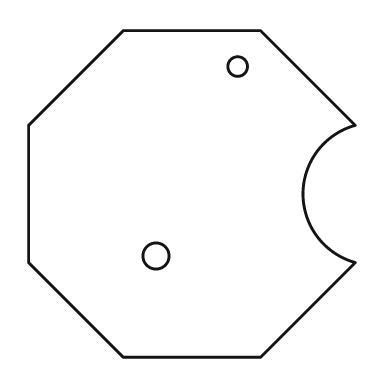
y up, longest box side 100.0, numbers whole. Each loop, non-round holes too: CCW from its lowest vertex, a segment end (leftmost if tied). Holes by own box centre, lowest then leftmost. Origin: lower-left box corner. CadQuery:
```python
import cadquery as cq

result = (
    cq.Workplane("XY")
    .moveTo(29.0, 0.0)
    .lineTo(71.0, 0.0)
    .lineTo(100.0, 29.0)
    .threePointArc((84.0, 50.0), (100.0, 71.0))
    .lineTo(71.0, 100.0)
    .lineTo(29.0, 100.0)
    .lineTo(0.0, 71.0)
    .lineTo(0.0, 29.0)
    .close()
    .moveTo(39.0, 31.0)
    .circle(4.0)
    .moveTo(64.0, 89.0)
    .circle(3.0)
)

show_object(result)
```